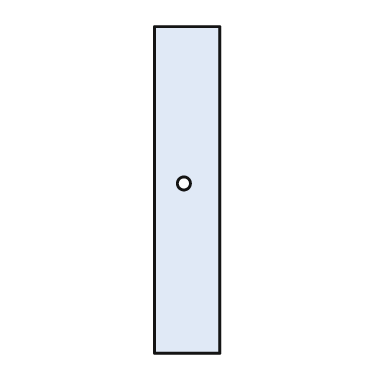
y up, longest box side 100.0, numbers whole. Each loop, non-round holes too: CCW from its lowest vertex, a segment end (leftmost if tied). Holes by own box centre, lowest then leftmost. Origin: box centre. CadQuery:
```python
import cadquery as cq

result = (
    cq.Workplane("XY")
    .moveTo(-10.0, -50.0)
    .lineTo(10.0, -50.0)
    .lineTo(10.0, 50.0)
    .lineTo(-10.0, 50.0)
    .close()
    .moveTo(-1.0, 2.0)
    .circle(2.0)
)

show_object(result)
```